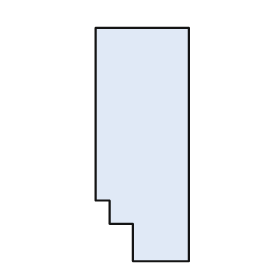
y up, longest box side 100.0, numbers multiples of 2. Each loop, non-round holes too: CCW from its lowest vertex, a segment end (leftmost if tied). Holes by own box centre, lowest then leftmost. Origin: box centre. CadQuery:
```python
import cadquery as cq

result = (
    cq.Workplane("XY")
    .moveTo(-4.0, -50.0)
    .lineTo(20.0, -50.0)
    .lineTo(20.0, 50.0)
    .lineTo(-20.0, 50.0)
    .lineTo(-20.0, -24.0)
    .lineTo(-14.0, -24.0)
    .lineTo(-14.0, -34.0)
    .lineTo(-4.0, -34.0)
    .close()
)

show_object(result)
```